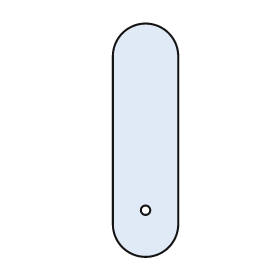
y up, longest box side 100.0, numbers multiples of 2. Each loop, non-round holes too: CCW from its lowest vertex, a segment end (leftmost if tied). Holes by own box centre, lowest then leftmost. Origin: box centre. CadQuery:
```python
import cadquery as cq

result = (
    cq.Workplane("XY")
    .moveTo(-14.0, -36.0)
    .threePointArc((0.0, -50.0), (14.0, -36.0))
    .lineTo(14.0, 36.0)
    .threePointArc((0.0, 50.0), (-14.0, 36.0))
    .close()
    .moveTo(0.0, -30.0)
    .circle(2.0)
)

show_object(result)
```